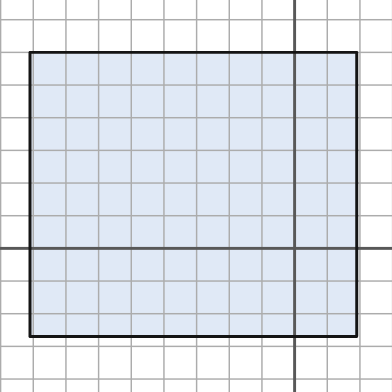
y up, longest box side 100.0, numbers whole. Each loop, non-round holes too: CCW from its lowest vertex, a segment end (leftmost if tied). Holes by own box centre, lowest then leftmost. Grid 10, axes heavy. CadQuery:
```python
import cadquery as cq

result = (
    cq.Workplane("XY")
    .moveTo(-81.0, -27.0)
    .lineTo(19.0, -27.0)
    .lineTo(19.0, 60.0)
    .lineTo(-81.0, 60.0)
    .close()
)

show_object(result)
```